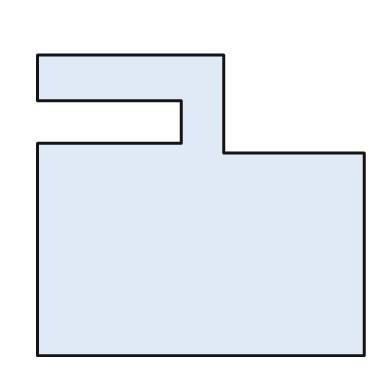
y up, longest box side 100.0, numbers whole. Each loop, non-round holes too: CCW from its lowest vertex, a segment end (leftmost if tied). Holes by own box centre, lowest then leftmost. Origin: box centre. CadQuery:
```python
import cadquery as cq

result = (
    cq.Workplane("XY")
    .moveTo(-50.0, -46.0)
    .lineTo(50.0, -46.0)
    .lineTo(50.0, 16.0)
    .lineTo(7.0, 16.0)
    .lineTo(7.0, 46.0)
    .lineTo(-50.0, 46.0)
    .lineTo(-50.0, 32.0)
    .lineTo(-6.0, 32.0)
    .lineTo(-6.0, 19.0)
    .lineTo(-50.0, 19.0)
    .close()
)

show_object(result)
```